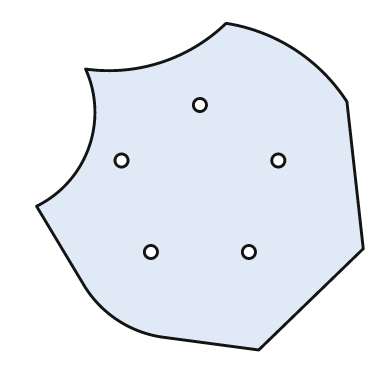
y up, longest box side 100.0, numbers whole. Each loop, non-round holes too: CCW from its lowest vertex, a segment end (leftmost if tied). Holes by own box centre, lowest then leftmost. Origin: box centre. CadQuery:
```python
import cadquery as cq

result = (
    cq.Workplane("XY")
    .moveTo(18.0, -50.0)
    .lineTo(50.0, -19.0)
    .lineTo(45.0, 26.0)
    .threePointArc((29.0, 42.0), (8.0, 50.0))
    .threePointArc((-12.0, 38.0), (-35.0, 36.0))
    .threePointArc((-34.0, 12.0), (-50.0, -6.0))
    .lineTo(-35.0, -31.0)
    .threePointArc((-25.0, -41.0), (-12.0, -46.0))
    .close()
    .moveTo(-15.0, -20.0)
    .circle(2.0)
    .moveTo(15.0, -20.0)
    .circle(2.0)
    .moveTo(-24.0, 8.0)
    .circle(2.0)
    .moveTo(24.0, 8.0)
    .circle(2.0)
    .moveTo(0.0, 25.0)
    .circle(2.0)
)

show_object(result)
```